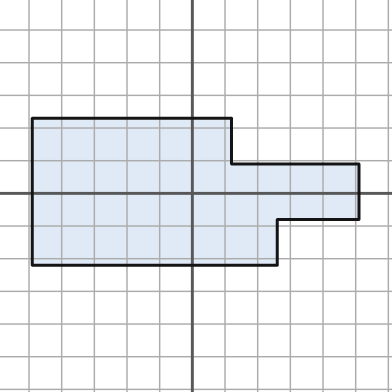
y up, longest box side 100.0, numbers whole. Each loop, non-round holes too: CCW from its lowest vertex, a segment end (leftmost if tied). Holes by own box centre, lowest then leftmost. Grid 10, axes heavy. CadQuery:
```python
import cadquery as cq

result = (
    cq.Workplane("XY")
    .moveTo(-49.0, -22.0)
    .lineTo(26.0, -22.0)
    .lineTo(26.0, -8.0)
    .lineTo(51.0, -8.0)
    .lineTo(51.0, 9.0)
    .lineTo(12.0, 9.0)
    .lineTo(12.0, 23.0)
    .lineTo(-49.0, 23.0)
    .close()
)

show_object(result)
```